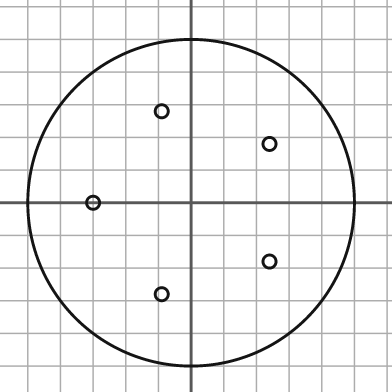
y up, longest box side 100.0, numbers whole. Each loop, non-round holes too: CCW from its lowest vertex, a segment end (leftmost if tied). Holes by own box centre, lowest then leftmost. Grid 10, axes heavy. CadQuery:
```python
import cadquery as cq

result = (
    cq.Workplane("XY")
    .moveTo(0.0, 0.0)
    .circle(50.0)
    .moveTo(-9.0, -28.0)
    .circle(2.0)
    .moveTo(24.0, -18.0)
    .circle(2.0)
    .moveTo(-30.0, 0.0)
    .circle(2.0)
    .moveTo(24.0, 18.0)
    .circle(2.0)
    .moveTo(-9.0, 28.0)
    .circle(2.0)
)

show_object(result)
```